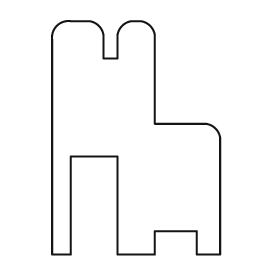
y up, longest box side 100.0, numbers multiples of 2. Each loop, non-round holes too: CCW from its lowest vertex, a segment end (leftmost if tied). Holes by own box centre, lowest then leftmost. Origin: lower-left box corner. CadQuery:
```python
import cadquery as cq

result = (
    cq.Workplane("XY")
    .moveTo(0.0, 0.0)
    .lineTo(8.0, 0.0)
    .lineTo(8.0, 42.0)
    .lineTo(28.0, 42.0)
    .lineTo(28.0, 0.0)
    .lineTo(44.0, 0.0)
    .lineTo(44.0, 10.0)
    .lineTo(62.0, 10.0)
    .lineTo(62.0, 0.0)
    .lineTo(72.0, 0.0)
    .lineTo(72.0, 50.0)
    .threePointArc((70.0, 54.0), (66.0, 56.0))
    .lineTo(44.0, 56.0)
    .lineTo(44.0, 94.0)
    .threePointArc((42.0, 98.0), (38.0, 100.0))
    .lineTo(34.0, 100.0)
    .threePointArc((30.0, 98.0), (28.0, 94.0))
    .lineTo(28.0, 84.0)
    .lineTo(22.0, 84.0)
    .lineTo(22.0, 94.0)
    .threePointArc((20.0, 98.0), (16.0, 100.0))
    .lineTo(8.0, 100.0)
    .threePointArc((2.0, 98.0), (0.0, 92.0))
    .close()
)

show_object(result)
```